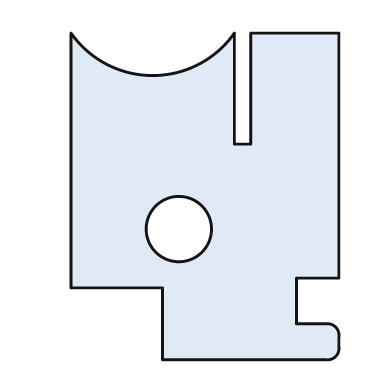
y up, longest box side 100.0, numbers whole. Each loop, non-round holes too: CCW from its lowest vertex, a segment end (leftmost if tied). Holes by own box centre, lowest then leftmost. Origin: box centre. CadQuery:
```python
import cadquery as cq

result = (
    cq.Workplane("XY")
    .moveTo(-13.0, -50.0)
    .lineTo(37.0, -50.0)
    .threePointArc((40.0, -49.0), (41.0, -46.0))
    .lineTo(41.0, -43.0)
    .threePointArc((40.0, -40.0), (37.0, -39.0))
    .lineTo(28.0, -39.0)
    .lineTo(28.0, -25.0)
    .lineTo(41.0, -25.0)
    .lineTo(41.0, 50.0)
    .lineTo(14.0, 50.0)
    .lineTo(14.0, 16.0)
    .lineTo(9.0, 16.0)
    .lineTo(9.0, 50.0)
    .threePointArc((-16.0, 37.0), (-41.0, 50.0))
    .lineTo(-41.0, -28.0)
    .lineTo(-13.0, -28.0)
    .close()
    .moveTo(-8.0, -10.0)
    .circle(10.0)
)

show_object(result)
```